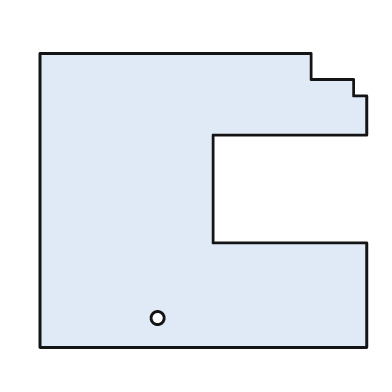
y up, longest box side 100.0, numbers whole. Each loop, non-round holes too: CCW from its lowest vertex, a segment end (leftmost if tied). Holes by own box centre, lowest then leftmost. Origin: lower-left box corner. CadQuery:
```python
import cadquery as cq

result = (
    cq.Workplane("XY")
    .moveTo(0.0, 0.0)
    .lineTo(100.0, 0.0)
    .lineTo(100.0, 32.0)
    .lineTo(53.0, 32.0)
    .lineTo(53.0, 65.0)
    .lineTo(100.0, 65.0)
    .lineTo(100.0, 77.0)
    .lineTo(96.0, 77.0)
    .lineTo(96.0, 82.0)
    .lineTo(83.0, 82.0)
    .lineTo(83.0, 90.0)
    .lineTo(0.0, 90.0)
    .close()
    .moveTo(36.0, 9.0)
    .circle(2.0)
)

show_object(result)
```